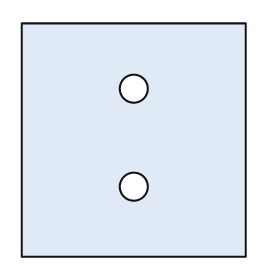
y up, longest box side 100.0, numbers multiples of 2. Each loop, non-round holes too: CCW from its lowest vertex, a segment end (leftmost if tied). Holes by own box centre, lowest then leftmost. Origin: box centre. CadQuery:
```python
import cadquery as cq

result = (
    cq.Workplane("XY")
    .moveTo(-48.0, -50.0)
    .lineTo(48.0, -50.0)
    .lineTo(48.0, 50.0)
    .lineTo(-48.0, 50.0)
    .close()
    .moveTo(0.0, -20.0)
    .circle(6.0)
    .moveTo(0.0, 22.0)
    .circle(6.0)
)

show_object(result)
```